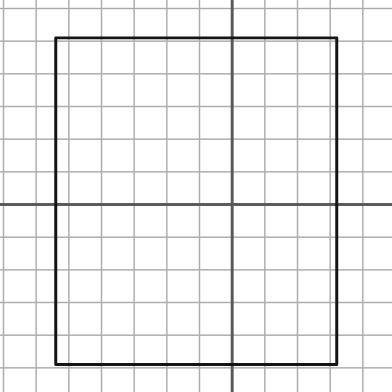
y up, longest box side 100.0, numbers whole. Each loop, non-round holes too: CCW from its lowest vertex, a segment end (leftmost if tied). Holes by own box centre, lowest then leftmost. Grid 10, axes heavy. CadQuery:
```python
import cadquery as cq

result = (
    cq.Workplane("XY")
    .moveTo(-54.0, -49.0)
    .lineTo(32.0, -49.0)
    .lineTo(32.0, 51.0)
    .lineTo(-54.0, 51.0)
    .close()
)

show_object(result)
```